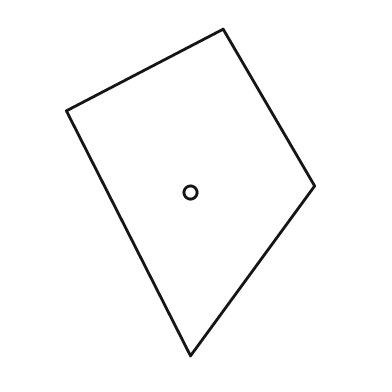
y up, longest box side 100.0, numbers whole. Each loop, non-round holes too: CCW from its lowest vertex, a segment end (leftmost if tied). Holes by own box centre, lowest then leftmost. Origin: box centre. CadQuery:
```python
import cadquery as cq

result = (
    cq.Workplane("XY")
    .moveTo(0.0, -50.0)
    .lineTo(38.0, 2.0)
    .lineTo(10.0, 50.0)
    .lineTo(-38.0, 25.0)
    .close()
    .moveTo(0.0, 0.0)
    .circle(2.0)
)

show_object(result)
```